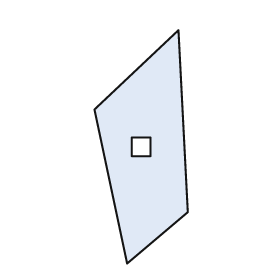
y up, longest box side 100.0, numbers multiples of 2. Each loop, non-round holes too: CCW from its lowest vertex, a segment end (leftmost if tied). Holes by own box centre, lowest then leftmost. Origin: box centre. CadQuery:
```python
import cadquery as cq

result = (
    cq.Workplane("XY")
    .moveTo(-6.0, -50.0)
    .lineTo(20.0, -28.0)
    .lineTo(16.0, 50.0)
    .lineTo(-20.0, 16.0)
    .close()
    .moveTo(-4.0, -4.0)
    .lineTo(4.0, -4.0)
    .lineTo(4.0, 4.0)
    .lineTo(-4.0, 4.0)
    .close()
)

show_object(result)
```